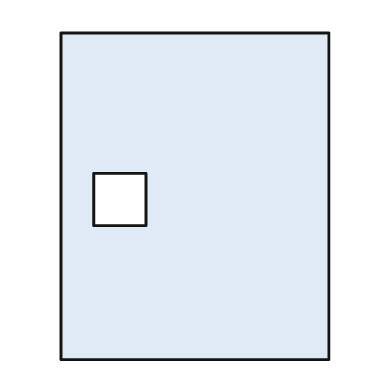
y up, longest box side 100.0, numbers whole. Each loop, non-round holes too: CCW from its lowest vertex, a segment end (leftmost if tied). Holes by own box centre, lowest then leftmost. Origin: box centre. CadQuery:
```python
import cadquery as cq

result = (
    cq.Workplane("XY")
    .moveTo(-41.0, -50.0)
    .lineTo(41.0, -50.0)
    .lineTo(41.0, 50.0)
    .lineTo(-41.0, 50.0)
    .close()
    .moveTo(-31.0, -9.0)
    .lineTo(-15.0, -9.0)
    .lineTo(-15.0, 7.0)
    .lineTo(-31.0, 7.0)
    .close()
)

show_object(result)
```